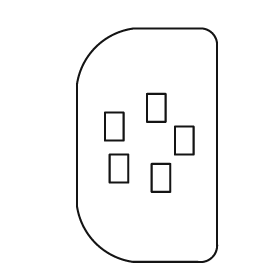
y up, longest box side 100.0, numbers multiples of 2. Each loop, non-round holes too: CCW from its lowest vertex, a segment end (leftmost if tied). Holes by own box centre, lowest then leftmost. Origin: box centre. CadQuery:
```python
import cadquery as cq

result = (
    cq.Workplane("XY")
    .moveTo(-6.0, -50.0)
    .lineTo(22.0, -50.0)
    .threePointArc((28.0, -48.0), (30.0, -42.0))
    .lineTo(30.0, 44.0)
    .threePointArc((28.0, 48.0), (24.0, 50.0))
    .lineTo(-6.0, 50.0)
    .threePointArc((-22.0, 42.0), (-30.0, 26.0))
    .lineTo(-30.0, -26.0)
    .threePointArc((-22.0, -42.0), (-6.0, -50.0))
    .close()
    .moveTo(2.0, -20.0)
    .lineTo(10.0, -20.0)
    .lineTo(10.0, -8.0)
    .lineTo(2.0, -8.0)
    .close()
    .moveTo(-16.0, -16.0)
    .lineTo(-8.0, -16.0)
    .lineTo(-8.0, -4.0)
    .lineTo(-16.0, -4.0)
    .close()
    .moveTo(12.0, -4.0)
    .lineTo(20.0, -4.0)
    .lineTo(20.0, 8.0)
    .lineTo(12.0, 8.0)
    .close()
    .moveTo(-18.0, 2.0)
    .lineTo(-10.0, 2.0)
    .lineTo(-10.0, 14.0)
    .lineTo(-18.0, 14.0)
    .close()
    .moveTo(0.0, 10.0)
    .lineTo(8.0, 10.0)
    .lineTo(8.0, 22.0)
    .lineTo(0.0, 22.0)
    .close()
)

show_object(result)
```